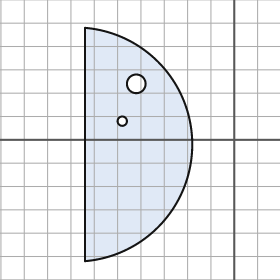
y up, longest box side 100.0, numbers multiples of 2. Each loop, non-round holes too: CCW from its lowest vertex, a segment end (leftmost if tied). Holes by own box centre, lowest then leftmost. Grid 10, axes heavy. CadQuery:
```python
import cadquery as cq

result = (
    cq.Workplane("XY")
    .moveTo(-64.0, -52.0)
    .threePointArc((-18.0, -2.0), (-64.0, 48.0))
    .close()
    .moveTo(-48.0, 8.0)
    .circle(2.0)
    .moveTo(-42.0, 24.0)
    .circle(4.0)
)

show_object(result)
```